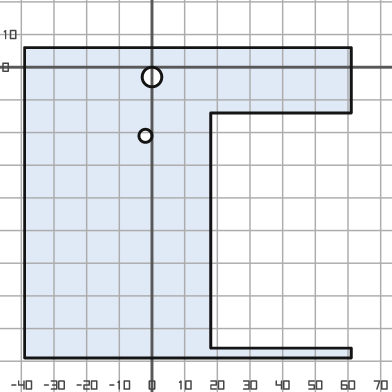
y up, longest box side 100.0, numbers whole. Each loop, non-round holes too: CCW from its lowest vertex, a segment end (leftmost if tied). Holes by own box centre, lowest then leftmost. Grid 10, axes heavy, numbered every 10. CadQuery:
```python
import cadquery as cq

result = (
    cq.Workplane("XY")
    .moveTo(-39.0, -89.0)
    .lineTo(61.0, -89.0)
    .lineTo(61.0, -86.0)
    .lineTo(18.0, -86.0)
    .lineTo(18.0, -14.0)
    .lineTo(61.0, -14.0)
    .lineTo(61.0, 6.0)
    .lineTo(-39.0, 6.0)
    .close()
    .moveTo(-2.0, -21.0)
    .circle(2.0)
    .moveTo(0.0, -3.0)
    .circle(3.0)
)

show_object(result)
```